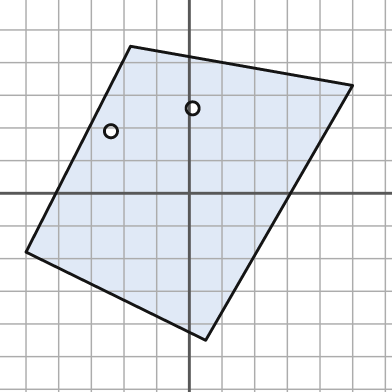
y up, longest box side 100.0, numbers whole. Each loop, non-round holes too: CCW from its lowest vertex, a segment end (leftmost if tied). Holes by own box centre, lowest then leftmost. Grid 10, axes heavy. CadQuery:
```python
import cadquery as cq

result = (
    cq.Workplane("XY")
    .moveTo(5.0, -45.0)
    .lineTo(50.0, 33.0)
    .lineTo(-18.0, 45.0)
    .lineTo(-50.0, -18.0)
    .close()
    .moveTo(-24.0, 19.0)
    .circle(2.0)
    .moveTo(1.0, 26.0)
    .circle(2.0)
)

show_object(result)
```